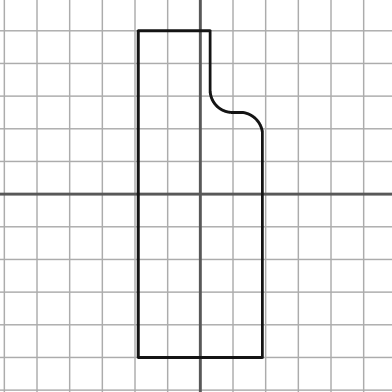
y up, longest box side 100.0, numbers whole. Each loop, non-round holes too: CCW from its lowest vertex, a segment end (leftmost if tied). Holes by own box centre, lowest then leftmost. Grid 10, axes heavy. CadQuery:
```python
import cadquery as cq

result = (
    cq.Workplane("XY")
    .moveTo(-19.0, -50.0)
    .lineTo(19.0, -50.0)
    .lineTo(19.0, 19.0)
    .threePointArc((17.0, 23.0), (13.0, 25.0))
    .lineTo(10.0, 25.0)
    .threePointArc((5.0, 27.0), (3.0, 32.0))
    .lineTo(3.0, 50.0)
    .lineTo(-19.0, 50.0)
    .close()
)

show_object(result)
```